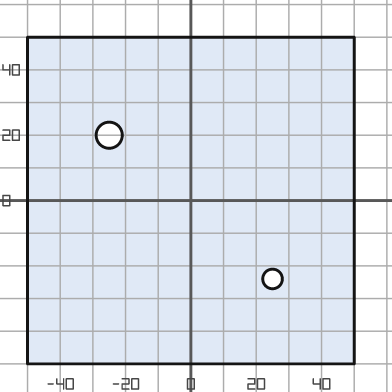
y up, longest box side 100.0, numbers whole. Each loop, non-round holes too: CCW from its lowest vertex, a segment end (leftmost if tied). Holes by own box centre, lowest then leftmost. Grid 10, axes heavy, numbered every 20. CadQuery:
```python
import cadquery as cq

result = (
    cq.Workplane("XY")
    .moveTo(-50.0, -50.0)
    .lineTo(50.0, -50.0)
    .lineTo(50.0, 50.0)
    .lineTo(-50.0, 50.0)
    .close()
    .moveTo(25.0, -24.0)
    .circle(3.0)
    .moveTo(-25.0, 20.0)
    .circle(4.0)
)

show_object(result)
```